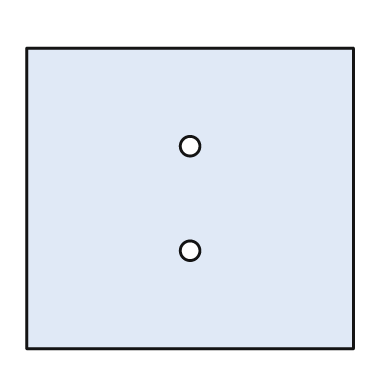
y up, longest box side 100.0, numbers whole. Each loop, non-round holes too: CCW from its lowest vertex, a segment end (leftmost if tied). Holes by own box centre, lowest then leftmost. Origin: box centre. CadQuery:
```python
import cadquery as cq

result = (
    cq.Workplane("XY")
    .moveTo(-50.0, -46.0)
    .lineTo(50.0, -46.0)
    .lineTo(50.0, 46.0)
    .lineTo(-50.0, 46.0)
    .close()
    .moveTo(0.0, -16.0)
    .circle(3.0)
    .moveTo(0.0, 16.0)
    .circle(3.0)
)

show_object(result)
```